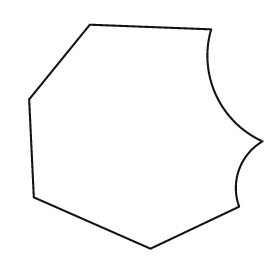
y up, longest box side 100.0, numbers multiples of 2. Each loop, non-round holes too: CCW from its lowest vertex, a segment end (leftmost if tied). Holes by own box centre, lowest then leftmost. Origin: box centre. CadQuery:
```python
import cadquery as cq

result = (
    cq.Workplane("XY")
    .moveTo(2.0, -48.0)
    .lineTo(40.0, -30.0)
    .threePointArc((40.0, -14.0), (50.0, -2.0))
    .threePointArc((30.0, 18.0), (28.0, 46.0))
    .lineTo(-24.0, 48.0)
    .lineTo(-50.0, 16.0)
    .lineTo(-48.0, -26.0)
    .close()
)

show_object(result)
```